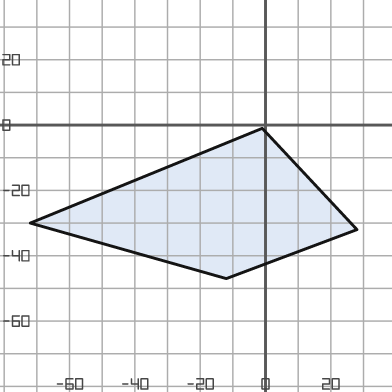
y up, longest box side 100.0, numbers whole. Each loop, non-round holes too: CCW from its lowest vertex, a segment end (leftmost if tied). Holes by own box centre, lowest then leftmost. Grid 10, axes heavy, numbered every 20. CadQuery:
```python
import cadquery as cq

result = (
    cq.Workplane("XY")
    .moveTo(-12.0, -47.0)
    .lineTo(28.0, -32.0)
    .lineTo(-1.0, -1.0)
    .lineTo(-72.0, -30.0)
    .close()
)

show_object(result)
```